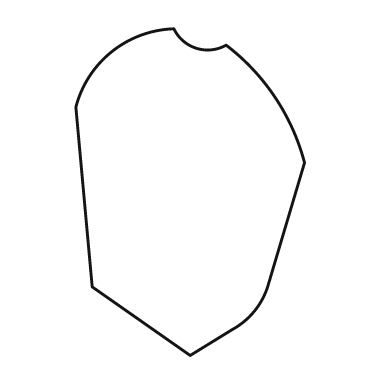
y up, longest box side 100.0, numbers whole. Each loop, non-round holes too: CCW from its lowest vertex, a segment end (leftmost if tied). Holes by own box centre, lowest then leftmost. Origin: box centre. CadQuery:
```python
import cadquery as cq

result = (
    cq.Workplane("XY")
    .moveTo(0.0, -50.0)
    .lineTo(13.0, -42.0)
    .threePointArc((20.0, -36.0), (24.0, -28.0))
    .lineTo(35.0, 9.0)
    .threePointArc((26.0, 29.0), (11.0, 45.0))
    .threePointArc((2.0, 44.0), (-5.0, 50.0))
    .threePointArc((-24.0, 43.0), (-35.0, 26.0))
    .lineTo(-30.0, -29.0)
    .close()
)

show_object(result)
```